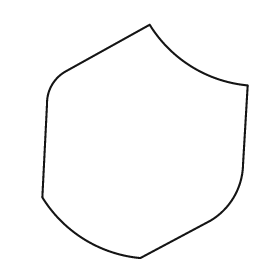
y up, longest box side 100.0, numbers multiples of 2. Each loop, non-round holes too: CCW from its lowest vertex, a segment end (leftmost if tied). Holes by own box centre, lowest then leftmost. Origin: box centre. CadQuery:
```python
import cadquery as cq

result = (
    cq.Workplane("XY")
    .moveTo(-2.0, -50.0)
    .lineTo(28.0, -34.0)
    .threePointArc((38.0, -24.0), (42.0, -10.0))
    .lineTo(44.0, 24.0)
    .threePointArc((20.0, 32.0), (2.0, 50.0))
    .lineTo(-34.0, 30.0)
    .threePointArc((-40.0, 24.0), (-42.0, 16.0))
    .lineTo(-44.0, -24.0)
    .threePointArc((-26.0, -42.0), (-2.0, -50.0))
    .close()
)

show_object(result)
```